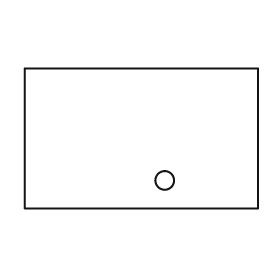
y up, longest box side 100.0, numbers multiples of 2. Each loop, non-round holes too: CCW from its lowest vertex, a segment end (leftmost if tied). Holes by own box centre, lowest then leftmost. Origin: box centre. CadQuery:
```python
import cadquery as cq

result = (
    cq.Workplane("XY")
    .moveTo(-50.0, -30.0)
    .lineTo(50.0, -30.0)
    .lineTo(50.0, 30.0)
    .lineTo(-50.0, 30.0)
    .close()
    .moveTo(10.0, -18.0)
    .circle(4.0)
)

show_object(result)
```